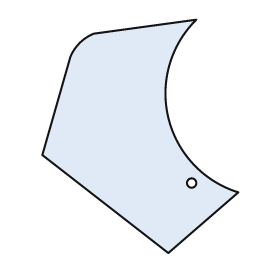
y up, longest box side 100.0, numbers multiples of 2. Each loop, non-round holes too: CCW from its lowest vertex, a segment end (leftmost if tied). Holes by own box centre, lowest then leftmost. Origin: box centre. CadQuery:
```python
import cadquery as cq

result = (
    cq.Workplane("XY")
    .moveTo(12.0, -50.0)
    .lineTo(42.0, -24.0)
    .threePointArc((12.0, 8.0), (24.0, 50.0))
    .lineTo(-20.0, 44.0)
    .threePointArc((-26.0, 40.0), (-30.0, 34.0))
    .lineTo(-42.0, -8.0)
    .close()
    .moveTo(22.0, -20.0)
    .circle(2.0)
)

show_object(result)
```